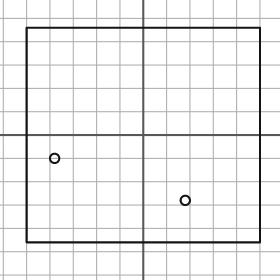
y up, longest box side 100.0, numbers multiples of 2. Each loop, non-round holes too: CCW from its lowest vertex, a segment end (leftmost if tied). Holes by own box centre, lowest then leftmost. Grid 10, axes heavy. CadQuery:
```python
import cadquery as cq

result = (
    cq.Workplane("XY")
    .moveTo(-50.0, -46.0)
    .lineTo(50.0, -46.0)
    .lineTo(50.0, 46.0)
    .lineTo(-50.0, 46.0)
    .close()
    .moveTo(18.0, -28.0)
    .circle(2.0)
    .moveTo(-38.0, -10.0)
    .circle(2.0)
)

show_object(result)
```